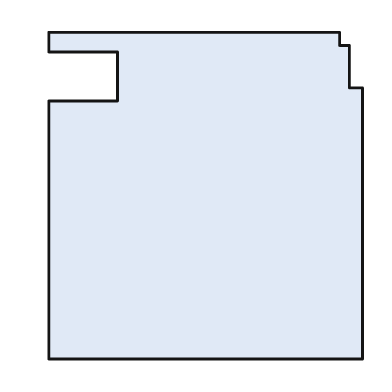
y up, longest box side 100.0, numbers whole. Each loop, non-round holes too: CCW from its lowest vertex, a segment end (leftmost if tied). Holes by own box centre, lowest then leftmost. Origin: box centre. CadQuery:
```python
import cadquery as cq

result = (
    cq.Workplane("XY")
    .moveTo(-48.0, -50.0)
    .lineTo(48.0, -50.0)
    .lineTo(48.0, 33.0)
    .lineTo(44.0, 33.0)
    .lineTo(44.0, 46.0)
    .lineTo(41.0, 46.0)
    .lineTo(41.0, 50.0)
    .lineTo(-48.0, 50.0)
    .lineTo(-48.0, 44.0)
    .lineTo(-27.0, 44.0)
    .lineTo(-27.0, 29.0)
    .lineTo(-48.0, 29.0)
    .close()
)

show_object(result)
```